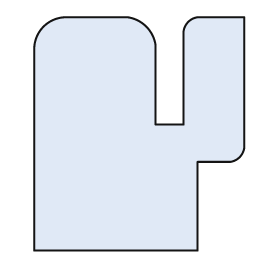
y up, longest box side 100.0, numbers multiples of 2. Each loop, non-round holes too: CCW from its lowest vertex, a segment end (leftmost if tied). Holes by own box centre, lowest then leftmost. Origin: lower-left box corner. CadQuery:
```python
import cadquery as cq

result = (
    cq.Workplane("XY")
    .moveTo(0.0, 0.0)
    .lineTo(70.0, 0.0)
    .lineTo(70.0, 38.0)
    .lineTo(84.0, 38.0)
    .threePointArc((88.0, 40.0), (90.0, 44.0))
    .lineTo(90.0, 100.0)
    .lineTo(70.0, 100.0)
    .threePointArc((66.0, 98.0), (64.0, 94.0))
    .lineTo(64.0, 54.0)
    .lineTo(52.0, 54.0)
    .lineTo(52.0, 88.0)
    .threePointArc((48.0, 96.0), (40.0, 100.0))
    .lineTo(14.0, 100.0)
    .threePointArc((4.0, 96.0), (0.0, 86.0))
    .close()
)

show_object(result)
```